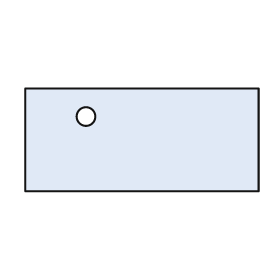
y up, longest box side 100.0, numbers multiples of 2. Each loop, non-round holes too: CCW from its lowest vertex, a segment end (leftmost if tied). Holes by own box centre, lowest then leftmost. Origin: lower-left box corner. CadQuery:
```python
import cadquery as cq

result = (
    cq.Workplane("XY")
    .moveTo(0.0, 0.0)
    .lineTo(100.0, 0.0)
    .lineTo(100.0, 44.0)
    .lineTo(0.0, 44.0)
    .close()
    .moveTo(26.0, 32.0)
    .circle(4.0)
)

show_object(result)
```